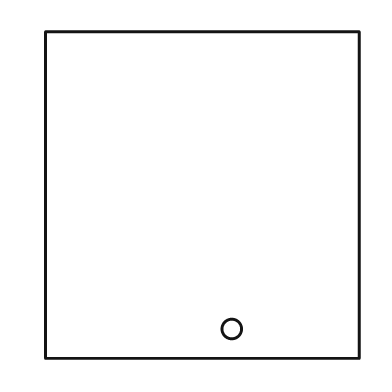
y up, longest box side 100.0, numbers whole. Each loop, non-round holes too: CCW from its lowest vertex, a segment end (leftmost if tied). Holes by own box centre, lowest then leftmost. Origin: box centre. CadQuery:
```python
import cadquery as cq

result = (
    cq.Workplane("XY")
    .moveTo(-48.0, -50.0)
    .lineTo(48.0, -50.0)
    .lineTo(48.0, 50.0)
    .lineTo(-48.0, 50.0)
    .close()
    .moveTo(9.0, -41.0)
    .circle(3.0)
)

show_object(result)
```